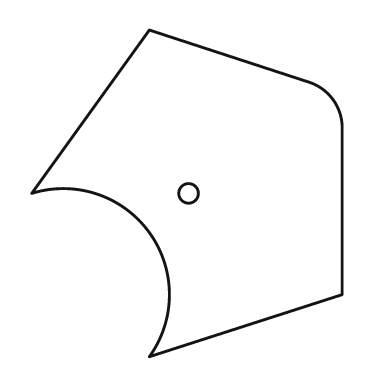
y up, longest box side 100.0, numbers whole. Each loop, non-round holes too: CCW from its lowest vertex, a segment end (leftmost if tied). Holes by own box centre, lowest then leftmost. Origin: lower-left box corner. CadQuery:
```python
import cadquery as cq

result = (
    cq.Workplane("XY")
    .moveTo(36.0, 0.0)
    .lineTo(95.0, 19.0)
    .lineTo(95.0, 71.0)
    .threePointArc((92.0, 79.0), (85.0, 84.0))
    .lineTo(36.0, 100.0)
    .lineTo(0.0, 50.0)
    .threePointArc((36.0, 38.0), (36.0, 0.0))
    .close()
    .moveTo(48.0, 50.0)
    .circle(3.0)
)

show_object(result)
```